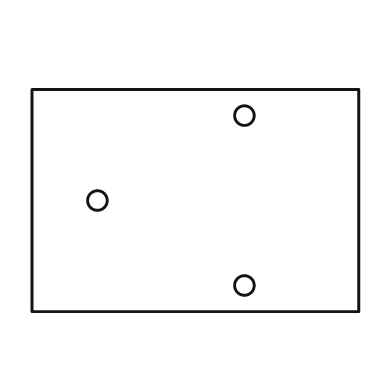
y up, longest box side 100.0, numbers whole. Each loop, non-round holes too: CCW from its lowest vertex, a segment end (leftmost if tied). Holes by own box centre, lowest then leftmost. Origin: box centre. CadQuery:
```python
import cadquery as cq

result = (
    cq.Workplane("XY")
    .moveTo(-50.0, -34.0)
    .lineTo(50.0, -34.0)
    .lineTo(50.0, 34.0)
    .lineTo(-50.0, 34.0)
    .close()
    .moveTo(15.0, -26.0)
    .circle(3.0)
    .moveTo(-30.0, 0.0)
    .circle(3.0)
    .moveTo(15.0, 26.0)
    .circle(3.0)
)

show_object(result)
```